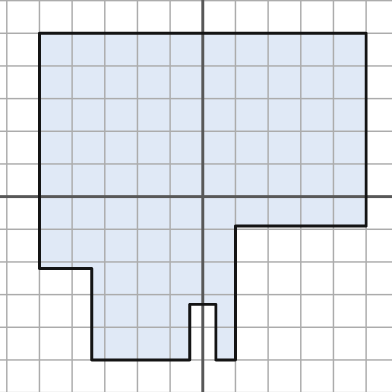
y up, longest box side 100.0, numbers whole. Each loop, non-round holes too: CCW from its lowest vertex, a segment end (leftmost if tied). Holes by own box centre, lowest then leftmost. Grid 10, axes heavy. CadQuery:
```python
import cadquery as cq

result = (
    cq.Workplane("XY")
    .moveTo(-34.0, -50.0)
    .lineTo(-4.0, -50.0)
    .lineTo(-4.0, -33.0)
    .lineTo(4.0, -33.0)
    .lineTo(4.0, -50.0)
    .lineTo(10.0, -50.0)
    .lineTo(10.0, -9.0)
    .lineTo(50.0, -9.0)
    .lineTo(50.0, 50.0)
    .lineTo(-50.0, 50.0)
    .lineTo(-50.0, -22.0)
    .lineTo(-34.0, -22.0)
    .close()
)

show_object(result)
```